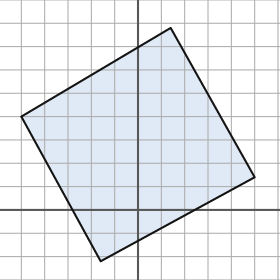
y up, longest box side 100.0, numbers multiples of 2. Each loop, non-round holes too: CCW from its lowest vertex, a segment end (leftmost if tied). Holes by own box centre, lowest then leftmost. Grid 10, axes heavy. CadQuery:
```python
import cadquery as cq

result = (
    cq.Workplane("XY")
    .moveTo(-16.0, -22.0)
    .lineTo(50.0, 14.0)
    .lineTo(14.0, 78.0)
    .lineTo(-50.0, 40.0)
    .close()
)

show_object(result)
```